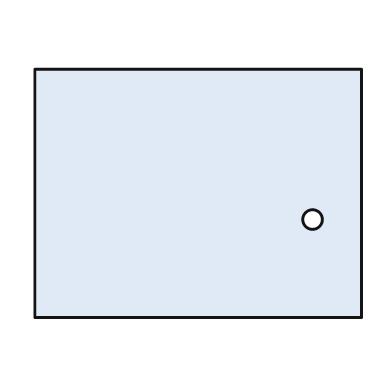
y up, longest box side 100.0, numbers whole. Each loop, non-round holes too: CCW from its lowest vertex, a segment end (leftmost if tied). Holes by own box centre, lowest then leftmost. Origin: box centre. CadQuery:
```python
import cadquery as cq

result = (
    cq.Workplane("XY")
    .moveTo(-50.0, -38.0)
    .lineTo(50.0, -38.0)
    .lineTo(50.0, 38.0)
    .lineTo(-50.0, 38.0)
    .close()
    .moveTo(35.0, -8.0)
    .circle(3.0)
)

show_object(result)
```